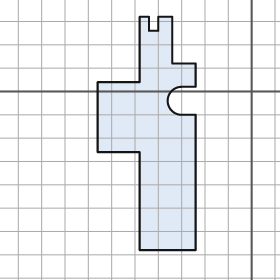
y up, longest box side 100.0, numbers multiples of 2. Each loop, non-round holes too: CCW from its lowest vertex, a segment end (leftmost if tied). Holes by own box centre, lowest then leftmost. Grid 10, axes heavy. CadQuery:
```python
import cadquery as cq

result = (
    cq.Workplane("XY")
    .moveTo(-48.0, -68.0)
    .lineTo(-24.0, -68.0)
    .lineTo(-24.0, -10.0)
    .lineTo(-30.0, -10.0)
    .threePointArc((-36.0, -4.0), (-30.0, 2.0))
    .lineTo(-24.0, 2.0)
    .lineTo(-24.0, 12.0)
    .lineTo(-34.0, 12.0)
    .lineTo(-34.0, 32.0)
    .lineTo(-40.0, 32.0)
    .lineTo(-40.0, 26.0)
    .lineTo(-44.0, 26.0)
    .lineTo(-44.0, 32.0)
    .lineTo(-48.0, 32.0)
    .lineTo(-48.0, 4.0)
    .lineTo(-66.0, 4.0)
    .lineTo(-66.0, -26.0)
    .lineTo(-48.0, -26.0)
    .close()
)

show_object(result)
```